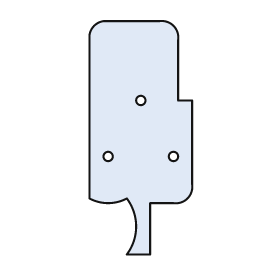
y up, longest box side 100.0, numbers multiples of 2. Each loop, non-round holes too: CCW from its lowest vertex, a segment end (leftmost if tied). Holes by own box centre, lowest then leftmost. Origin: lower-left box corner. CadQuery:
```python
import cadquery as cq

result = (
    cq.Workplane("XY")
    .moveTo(16.0, 0.0)
    .lineTo(26.0, 0.0)
    .lineTo(26.0, 22.0)
    .lineTo(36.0, 22.0)
    .threePointArc((42.0, 24.0), (44.0, 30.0))
    .lineTo(44.0, 66.0)
    .lineTo(38.0, 66.0)
    .lineTo(38.0, 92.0)
    .threePointArc((36.0, 98.0), (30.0, 100.0))
    .lineTo(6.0, 100.0)
    .threePointArc((2.0, 98.0), (0.0, 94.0))
    .lineTo(0.0, 24.0)
    .threePointArc((8.0, 22.0), (16.0, 24.0))
    .threePointArc((20.0, 12.0), (16.0, 0.0))
    .close()
    .moveTo(8.0, 42.0)
    .circle(2.0)
    .moveTo(36.0, 42.0)
    .circle(2.0)
    .moveTo(22.0, 66.0)
    .circle(2.0)
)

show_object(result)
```